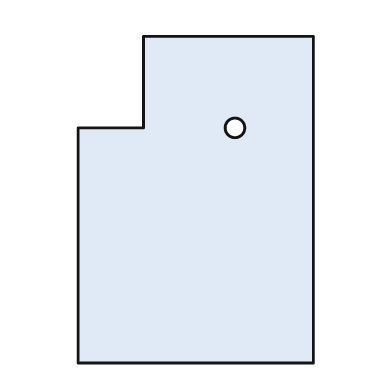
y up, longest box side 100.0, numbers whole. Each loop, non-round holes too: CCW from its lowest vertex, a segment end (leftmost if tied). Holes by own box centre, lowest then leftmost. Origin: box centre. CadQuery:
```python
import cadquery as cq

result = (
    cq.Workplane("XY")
    .moveTo(-36.0, -50.0)
    .lineTo(36.0, -50.0)
    .lineTo(36.0, 50.0)
    .lineTo(-16.0, 50.0)
    .lineTo(-16.0, 22.0)
    .lineTo(-36.0, 22.0)
    .close()
    .moveTo(12.0, 22.0)
    .circle(3.0)
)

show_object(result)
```